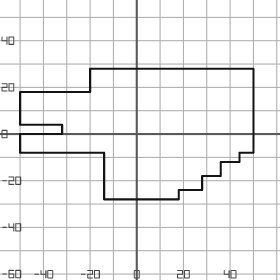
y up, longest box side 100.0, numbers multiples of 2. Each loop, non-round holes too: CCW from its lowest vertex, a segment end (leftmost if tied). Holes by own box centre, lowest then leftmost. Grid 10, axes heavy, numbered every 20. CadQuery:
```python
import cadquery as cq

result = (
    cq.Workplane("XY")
    .moveTo(-14.0, -28.0)
    .lineTo(18.0, -28.0)
    .lineTo(18.0, -24.0)
    .lineTo(28.0, -24.0)
    .lineTo(28.0, -18.0)
    .lineTo(36.0, -18.0)
    .lineTo(36.0, -12.0)
    .lineTo(44.0, -12.0)
    .lineTo(44.0, -8.0)
    .lineTo(50.0, -8.0)
    .lineTo(50.0, 28.0)
    .lineTo(-20.0, 28.0)
    .lineTo(-20.0, 18.0)
    .lineTo(-50.0, 18.0)
    .lineTo(-50.0, 4.0)
    .lineTo(-32.0, 4.0)
    .lineTo(-32.0, 0.0)
    .lineTo(-50.0, 0.0)
    .lineTo(-50.0, -8.0)
    .lineTo(-14.0, -8.0)
    .close()
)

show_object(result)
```